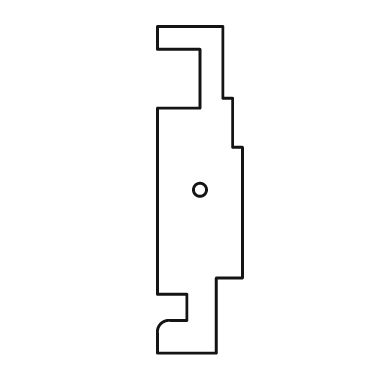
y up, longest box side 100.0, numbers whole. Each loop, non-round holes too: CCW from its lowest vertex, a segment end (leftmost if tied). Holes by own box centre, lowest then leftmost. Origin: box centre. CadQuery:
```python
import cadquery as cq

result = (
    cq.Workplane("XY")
    .moveTo(-13.0, -50.0)
    .lineTo(5.0, -50.0)
    .lineTo(5.0, -27.0)
    .lineTo(13.0, -27.0)
    .lineTo(13.0, 13.0)
    .lineTo(10.0, 13.0)
    .lineTo(10.0, 28.0)
    .lineTo(7.0, 28.0)
    .lineTo(7.0, 50.0)
    .lineTo(-13.0, 50.0)
    .lineTo(-13.0, 43.0)
    .lineTo(0.0, 43.0)
    .lineTo(0.0, 25.0)
    .lineTo(-13.0, 25.0)
    .lineTo(-13.0, -32.0)
    .lineTo(-4.0, -32.0)
    .lineTo(-4.0, -40.0)
    .lineTo(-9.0, -40.0)
    .threePointArc((-12.0, -41.0), (-13.0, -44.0))
    .close()
    .moveTo(0.0, 0.0)
    .circle(2.0)
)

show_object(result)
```